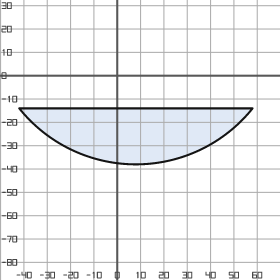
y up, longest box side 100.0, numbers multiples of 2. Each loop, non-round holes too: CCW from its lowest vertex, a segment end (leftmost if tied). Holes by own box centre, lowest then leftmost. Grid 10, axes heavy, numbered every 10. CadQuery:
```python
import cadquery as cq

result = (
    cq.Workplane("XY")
    .moveTo(-42.0, -14.0)
    .threePointArc((8.0, -38.0), (58.0, -14.0))
    .close()
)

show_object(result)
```